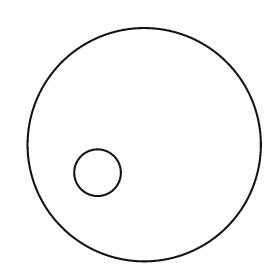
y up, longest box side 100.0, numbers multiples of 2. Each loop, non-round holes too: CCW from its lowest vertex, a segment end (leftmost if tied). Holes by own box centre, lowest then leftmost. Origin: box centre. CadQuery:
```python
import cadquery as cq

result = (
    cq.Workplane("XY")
    .moveTo(0.0, 0.0)
    .circle(50.0)
    .moveTo(-20.0, -12.0)
    .circle(10.0)
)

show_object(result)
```